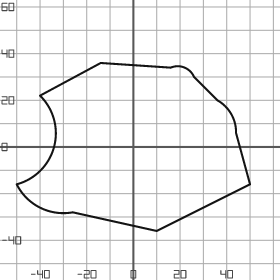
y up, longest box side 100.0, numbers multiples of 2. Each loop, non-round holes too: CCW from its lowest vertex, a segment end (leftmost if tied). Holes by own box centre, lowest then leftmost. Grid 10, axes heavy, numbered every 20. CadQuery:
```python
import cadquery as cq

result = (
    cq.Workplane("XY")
    .moveTo(10.0, -36.0)
    .lineTo(50.0, -16.0)
    .lineTo(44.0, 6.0)
    .threePointArc((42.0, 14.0), (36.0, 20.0))
    .lineTo(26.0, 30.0)
    .threePointArc((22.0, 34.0), (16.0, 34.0))
    .lineTo(-14.0, 36.0)
    .lineTo(-40.0, 22.0)
    .threePointArc((-34.0, 0.0), (-50.0, -16.0))
    .threePointArc((-40.0, -26.0), (-26.0, -28.0))
    .close()
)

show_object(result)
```